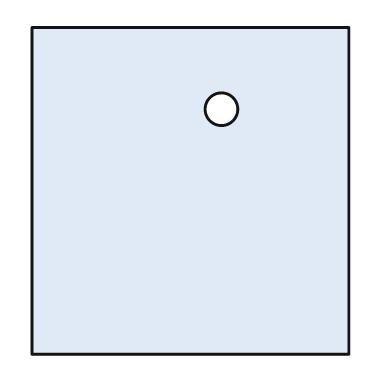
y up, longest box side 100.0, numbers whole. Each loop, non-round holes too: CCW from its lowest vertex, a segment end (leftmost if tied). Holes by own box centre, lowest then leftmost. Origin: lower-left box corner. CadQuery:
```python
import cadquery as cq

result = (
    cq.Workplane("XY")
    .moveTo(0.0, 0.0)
    .lineTo(97.0, 0.0)
    .lineTo(97.0, 100.0)
    .lineTo(0.0, 100.0)
    .close()
    .moveTo(58.0, 75.0)
    .circle(5.0)
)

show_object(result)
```